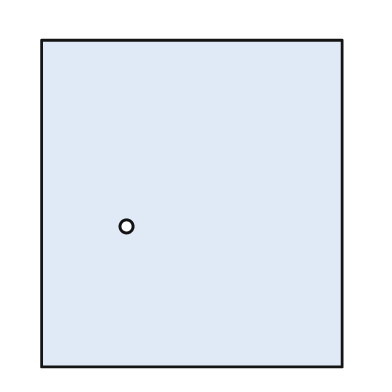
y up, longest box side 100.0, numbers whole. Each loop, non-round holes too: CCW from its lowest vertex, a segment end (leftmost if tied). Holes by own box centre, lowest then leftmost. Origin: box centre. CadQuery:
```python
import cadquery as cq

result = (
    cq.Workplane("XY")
    .moveTo(-46.0, -50.0)
    .lineTo(46.0, -50.0)
    .lineTo(46.0, 50.0)
    .lineTo(-46.0, 50.0)
    .close()
    .moveTo(-20.0, -7.0)
    .circle(2.0)
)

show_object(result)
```